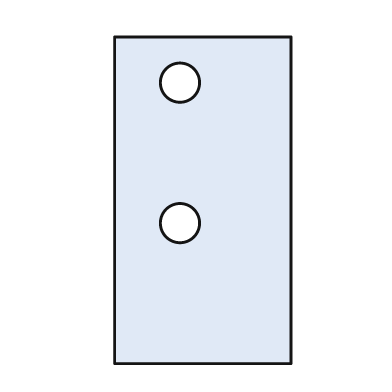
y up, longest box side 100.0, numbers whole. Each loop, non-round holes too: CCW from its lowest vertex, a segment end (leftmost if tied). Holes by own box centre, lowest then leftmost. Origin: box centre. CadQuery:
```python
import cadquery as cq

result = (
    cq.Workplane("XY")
    .moveTo(-27.0, -50.0)
    .lineTo(27.0, -50.0)
    .lineTo(27.0, 50.0)
    .lineTo(-27.0, 50.0)
    .close()
    .moveTo(-7.0, -7.0)
    .circle(6.0)
    .moveTo(-7.0, 36.0)
    .circle(6.0)
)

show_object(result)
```